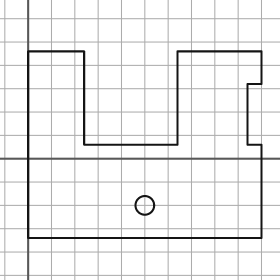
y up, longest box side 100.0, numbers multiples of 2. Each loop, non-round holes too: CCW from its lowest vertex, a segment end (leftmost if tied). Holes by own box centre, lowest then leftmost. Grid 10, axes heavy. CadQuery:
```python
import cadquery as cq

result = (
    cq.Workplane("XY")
    .moveTo(0.0, -34.0)
    .lineTo(100.0, -34.0)
    .lineTo(100.0, 6.0)
    .lineTo(94.0, 6.0)
    .lineTo(94.0, 32.0)
    .lineTo(100.0, 32.0)
    .lineTo(100.0, 46.0)
    .lineTo(64.0, 46.0)
    .lineTo(64.0, 6.0)
    .lineTo(24.0, 6.0)
    .lineTo(24.0, 46.0)
    .lineTo(0.0, 46.0)
    .close()
    .moveTo(50.0, -20.0)
    .circle(4.0)
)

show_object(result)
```